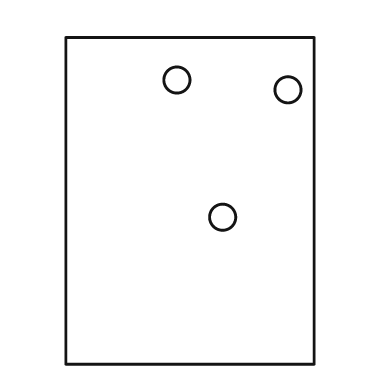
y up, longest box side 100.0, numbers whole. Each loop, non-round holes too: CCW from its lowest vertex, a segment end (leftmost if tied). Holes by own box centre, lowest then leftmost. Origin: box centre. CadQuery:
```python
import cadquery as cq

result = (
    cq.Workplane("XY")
    .moveTo(-38.0, -50.0)
    .lineTo(38.0, -50.0)
    .lineTo(38.0, 50.0)
    .lineTo(-38.0, 50.0)
    .close()
    .moveTo(10.0, -5.0)
    .circle(4.0)
    .moveTo(30.0, 34.0)
    .circle(4.0)
    .moveTo(-4.0, 37.0)
    .circle(4.0)
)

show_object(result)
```